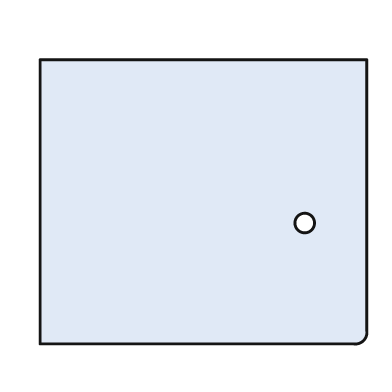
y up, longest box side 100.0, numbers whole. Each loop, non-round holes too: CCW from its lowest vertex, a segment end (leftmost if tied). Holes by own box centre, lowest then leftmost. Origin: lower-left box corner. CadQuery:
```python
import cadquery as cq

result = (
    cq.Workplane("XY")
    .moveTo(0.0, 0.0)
    .lineTo(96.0, 0.0)
    .threePointArc((99.0, 1.0), (100.0, 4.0))
    .lineTo(100.0, 87.0)
    .lineTo(0.0, 87.0)
    .close()
    .moveTo(81.0, 37.0)
    .circle(3.0)
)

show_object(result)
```